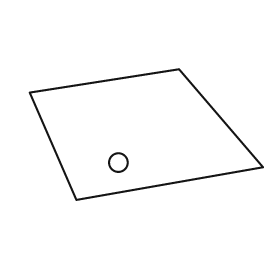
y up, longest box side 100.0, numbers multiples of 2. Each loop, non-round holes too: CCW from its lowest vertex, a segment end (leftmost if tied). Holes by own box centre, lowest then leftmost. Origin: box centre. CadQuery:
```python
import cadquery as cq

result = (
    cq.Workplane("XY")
    .moveTo(-30.0, -28.0)
    .lineTo(50.0, -14.0)
    .lineTo(14.0, 28.0)
    .lineTo(-50.0, 18.0)
    .close()
    .moveTo(-12.0, -12.0)
    .circle(4.0)
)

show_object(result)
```